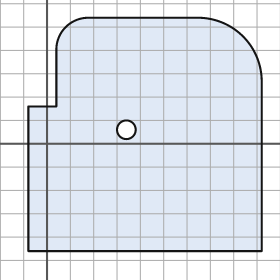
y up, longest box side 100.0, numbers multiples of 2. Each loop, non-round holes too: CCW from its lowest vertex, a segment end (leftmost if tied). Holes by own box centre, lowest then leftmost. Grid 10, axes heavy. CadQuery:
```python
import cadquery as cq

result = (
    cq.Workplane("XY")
    .moveTo(-8.0, -46.0)
    .lineTo(92.0, -46.0)
    .lineTo(92.0, 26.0)
    .threePointArc((84.0, 46.0), (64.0, 54.0))
    .lineTo(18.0, 54.0)
    .threePointArc((8.0, 50.0), (4.0, 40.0))
    .lineTo(4.0, 16.0)
    .lineTo(-8.0, 16.0)
    .close()
    .moveTo(34.0, 6.0)
    .circle(4.0)
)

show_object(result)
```